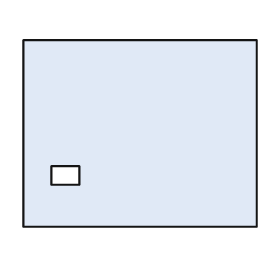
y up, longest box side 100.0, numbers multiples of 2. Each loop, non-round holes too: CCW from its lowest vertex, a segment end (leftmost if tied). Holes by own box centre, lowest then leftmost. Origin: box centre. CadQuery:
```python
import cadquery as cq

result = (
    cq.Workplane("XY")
    .moveTo(-50.0, -40.0)
    .lineTo(50.0, -40.0)
    .lineTo(50.0, 40.0)
    .lineTo(-50.0, 40.0)
    .close()
    .moveTo(-38.0, -22.0)
    .lineTo(-26.0, -22.0)
    .lineTo(-26.0, -14.0)
    .lineTo(-38.0, -14.0)
    .close()
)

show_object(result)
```